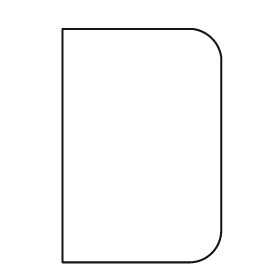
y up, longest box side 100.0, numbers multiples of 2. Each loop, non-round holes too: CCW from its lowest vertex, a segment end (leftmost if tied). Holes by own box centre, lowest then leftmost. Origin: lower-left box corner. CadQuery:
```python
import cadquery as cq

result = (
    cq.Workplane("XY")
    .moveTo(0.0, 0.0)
    .lineTo(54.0, 0.0)
    .threePointArc((64.0, 4.0), (68.0, 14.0))
    .lineTo(68.0, 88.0)
    .threePointArc((64.0, 96.0), (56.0, 100.0))
    .lineTo(0.0, 100.0)
    .close()
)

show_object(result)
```